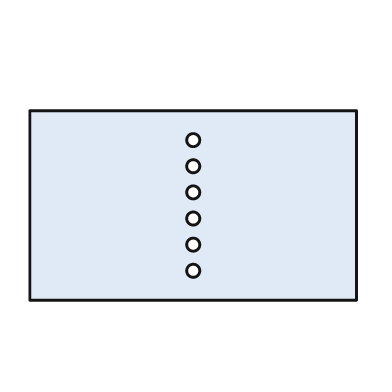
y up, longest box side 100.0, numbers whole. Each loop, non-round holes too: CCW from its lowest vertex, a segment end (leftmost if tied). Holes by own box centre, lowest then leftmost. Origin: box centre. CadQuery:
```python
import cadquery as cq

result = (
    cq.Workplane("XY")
    .moveTo(-50.0, -29.0)
    .lineTo(50.0, -29.0)
    .lineTo(50.0, 29.0)
    .lineTo(-50.0, 29.0)
    .close()
    .moveTo(0.0, -20.0)
    .circle(2.0)
    .moveTo(0.0, -12.0)
    .circle(2.0)
    .moveTo(0.0, -4.0)
    .circle(2.0)
    .moveTo(0.0, 4.0)
    .circle(2.0)
    .moveTo(0.0, 12.0)
    .circle(2.0)
    .moveTo(0.0, 20.0)
    .circle(2.0)
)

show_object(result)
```